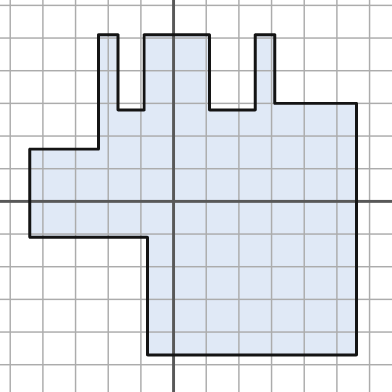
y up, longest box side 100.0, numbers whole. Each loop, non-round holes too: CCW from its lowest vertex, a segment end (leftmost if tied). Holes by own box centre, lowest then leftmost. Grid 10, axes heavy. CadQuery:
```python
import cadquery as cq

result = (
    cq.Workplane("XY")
    .moveTo(-8.0, -47.0)
    .lineTo(56.0, -47.0)
    .lineTo(56.0, 30.0)
    .lineTo(31.0, 30.0)
    .lineTo(31.0, 51.0)
    .lineTo(25.0, 51.0)
    .lineTo(25.0, 28.0)
    .lineTo(11.0, 28.0)
    .lineTo(11.0, 51.0)
    .lineTo(-9.0, 51.0)
    .lineTo(-9.0, 28.0)
    .lineTo(-17.0, 28.0)
    .lineTo(-17.0, 51.0)
    .lineTo(-23.0, 51.0)
    .lineTo(-23.0, 16.0)
    .lineTo(-44.0, 16.0)
    .lineTo(-44.0, -11.0)
    .lineTo(-8.0, -11.0)
    .close()
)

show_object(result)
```